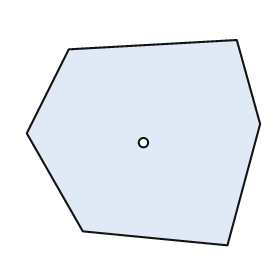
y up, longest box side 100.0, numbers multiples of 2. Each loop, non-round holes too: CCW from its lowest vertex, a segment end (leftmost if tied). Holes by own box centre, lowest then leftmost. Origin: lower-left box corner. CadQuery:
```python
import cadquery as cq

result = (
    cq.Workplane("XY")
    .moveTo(86.0, 0.0)
    .lineTo(100.0, 52.0)
    .lineTo(90.0, 88.0)
    .lineTo(18.0, 84.0)
    .lineTo(0.0, 48.0)
    .lineTo(24.0, 6.0)
    .close()
    .moveTo(50.0, 44.0)
    .circle(2.0)
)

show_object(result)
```